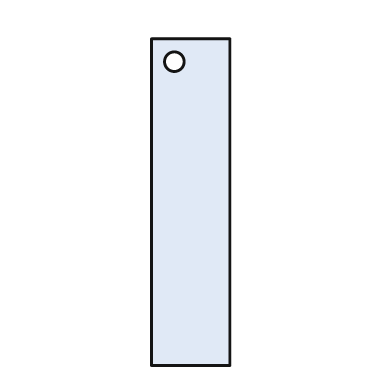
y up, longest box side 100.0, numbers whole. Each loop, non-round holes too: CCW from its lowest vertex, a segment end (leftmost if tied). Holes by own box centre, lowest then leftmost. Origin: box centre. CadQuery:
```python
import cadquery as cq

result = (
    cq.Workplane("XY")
    .moveTo(-12.0, -50.0)
    .lineTo(12.0, -50.0)
    .lineTo(12.0, 50.0)
    .lineTo(-12.0, 50.0)
    .close()
    .moveTo(-5.0, 43.0)
    .circle(3.0)
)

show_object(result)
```